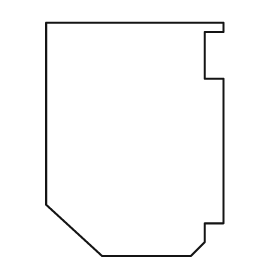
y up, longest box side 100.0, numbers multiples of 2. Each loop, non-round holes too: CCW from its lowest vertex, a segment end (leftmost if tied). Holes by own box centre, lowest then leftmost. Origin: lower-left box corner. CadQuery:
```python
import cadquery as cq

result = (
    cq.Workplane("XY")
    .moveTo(24.0, 0.0)
    .lineTo(62.0, 0.0)
    .lineTo(68.0, 6.0)
    .lineTo(68.0, 14.0)
    .lineTo(76.0, 14.0)
    .lineTo(76.0, 76.0)
    .lineTo(68.0, 76.0)
    .lineTo(68.0, 96.0)
    .lineTo(76.0, 96.0)
    .lineTo(76.0, 100.0)
    .lineTo(0.0, 100.0)
    .lineTo(0.0, 22.0)
    .close()
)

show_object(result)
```